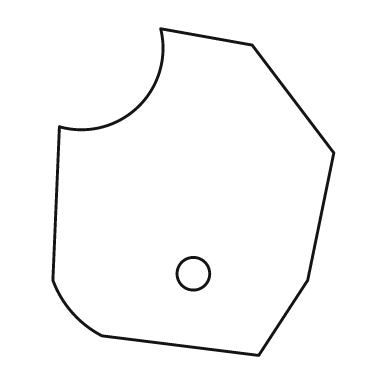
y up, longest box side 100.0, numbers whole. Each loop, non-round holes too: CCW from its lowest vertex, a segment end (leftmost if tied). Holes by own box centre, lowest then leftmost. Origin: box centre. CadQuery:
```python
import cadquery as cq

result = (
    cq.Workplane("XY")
    .moveTo(20.0, -50.0)
    .lineTo(35.0, -27.0)
    .lineTo(43.0, 12.0)
    .lineTo(18.0, 45.0)
    .lineTo(-10.0, 50.0)
    .threePointArc((-17.0, 26.0), (-41.0, 20.0))
    .lineTo(-43.0, -27.0)
    .threePointArc((-37.0, -37.0), (-28.0, -44.0))
    .close()
    .moveTo(0.0, -25.0)
    .circle(5.0)
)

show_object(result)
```